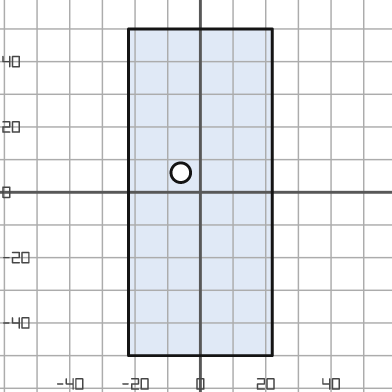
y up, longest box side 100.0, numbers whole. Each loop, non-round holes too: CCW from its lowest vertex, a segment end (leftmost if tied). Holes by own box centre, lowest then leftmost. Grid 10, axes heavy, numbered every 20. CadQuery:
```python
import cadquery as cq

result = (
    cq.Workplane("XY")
    .moveTo(-22.0, -50.0)
    .lineTo(22.0, -50.0)
    .lineTo(22.0, 50.0)
    .lineTo(-22.0, 50.0)
    .close()
    .moveTo(-6.0, 6.0)
    .circle(3.0)
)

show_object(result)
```